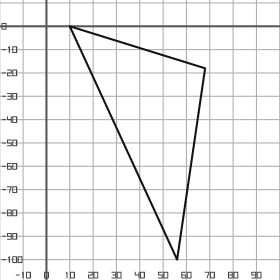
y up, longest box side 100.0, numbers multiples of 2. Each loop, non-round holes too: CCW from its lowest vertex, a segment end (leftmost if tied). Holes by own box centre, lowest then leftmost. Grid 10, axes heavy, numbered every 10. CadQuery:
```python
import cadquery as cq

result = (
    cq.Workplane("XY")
    .moveTo(56.0, -100.0)
    .lineTo(68.0, -18.0)
    .lineTo(10.0, 0.0)
    .close()
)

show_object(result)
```